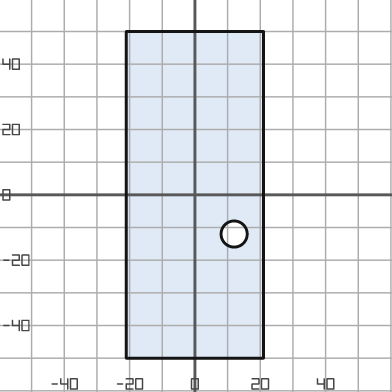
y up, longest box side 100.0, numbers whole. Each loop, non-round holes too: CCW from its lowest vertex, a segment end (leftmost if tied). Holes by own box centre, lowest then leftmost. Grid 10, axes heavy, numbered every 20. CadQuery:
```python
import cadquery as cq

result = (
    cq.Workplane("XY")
    .moveTo(-21.0, -50.0)
    .lineTo(21.0, -50.0)
    .lineTo(21.0, 50.0)
    .lineTo(-21.0, 50.0)
    .close()
    .moveTo(12.0, -12.0)
    .circle(4.0)
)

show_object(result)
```